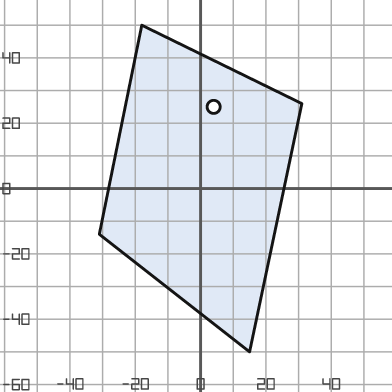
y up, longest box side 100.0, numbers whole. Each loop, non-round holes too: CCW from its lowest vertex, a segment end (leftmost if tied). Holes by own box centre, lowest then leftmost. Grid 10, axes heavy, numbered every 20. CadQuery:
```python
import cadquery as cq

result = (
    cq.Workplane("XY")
    .moveTo(15.0, -50.0)
    .lineTo(31.0, 26.0)
    .lineTo(-18.0, 50.0)
    .lineTo(-31.0, -14.0)
    .close()
    .moveTo(4.0, 25.0)
    .circle(2.0)
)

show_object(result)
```